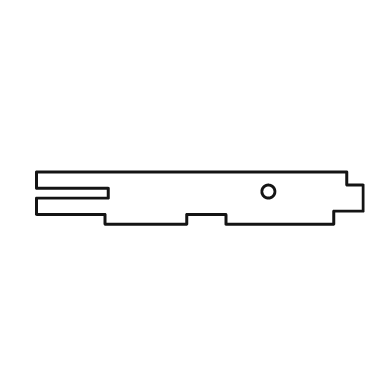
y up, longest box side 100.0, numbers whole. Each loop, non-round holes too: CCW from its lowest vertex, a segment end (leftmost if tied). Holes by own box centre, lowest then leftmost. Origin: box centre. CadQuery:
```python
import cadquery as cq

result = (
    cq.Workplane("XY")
    .moveTo(-29.0, -8.0)
    .lineTo(-4.0, -8.0)
    .lineTo(-4.0, -5.0)
    .lineTo(8.0, -5.0)
    .lineTo(8.0, -8.0)
    .lineTo(41.0, -8.0)
    .lineTo(41.0, -4.0)
    .lineTo(50.0, -4.0)
    .lineTo(50.0, 4.0)
    .lineTo(45.0, 4.0)
    .lineTo(45.0, 8.0)
    .lineTo(-50.0, 8.0)
    .lineTo(-50.0, 3.0)
    .lineTo(-28.0, 3.0)
    .lineTo(-28.0, 0.0)
    .lineTo(-50.0, 0.0)
    .lineTo(-50.0, -5.0)
    .lineTo(-29.0, -5.0)
    .close()
    .moveTo(21.0, 2.0)
    .circle(2.0)
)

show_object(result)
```